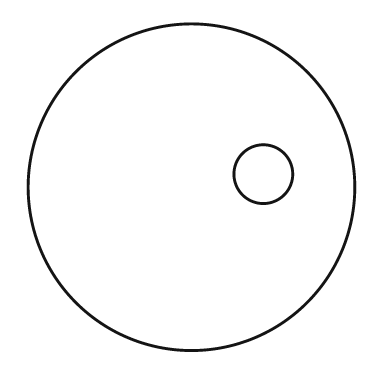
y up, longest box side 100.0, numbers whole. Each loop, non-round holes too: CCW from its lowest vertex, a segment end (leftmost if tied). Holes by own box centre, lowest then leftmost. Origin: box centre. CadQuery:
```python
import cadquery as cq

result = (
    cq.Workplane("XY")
    .moveTo(0.0, 0.0)
    .circle(50.0)
    .moveTo(22.0, 4.0)
    .circle(9.0)
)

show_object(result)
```